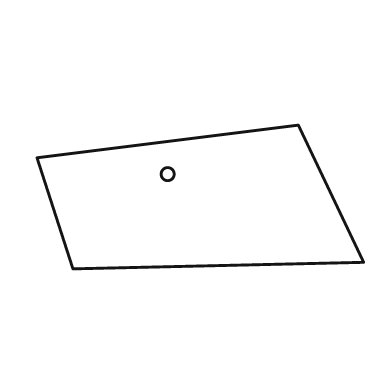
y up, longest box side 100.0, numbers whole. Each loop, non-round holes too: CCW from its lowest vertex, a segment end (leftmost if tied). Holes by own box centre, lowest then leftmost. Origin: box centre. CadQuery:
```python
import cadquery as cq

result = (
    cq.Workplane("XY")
    .moveTo(-39.0, -22.0)
    .lineTo(50.0, -20.0)
    .lineTo(30.0, 22.0)
    .lineTo(-50.0, 12.0)
    .close()
    .moveTo(-10.0, 7.0)
    .circle(2.0)
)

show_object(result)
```